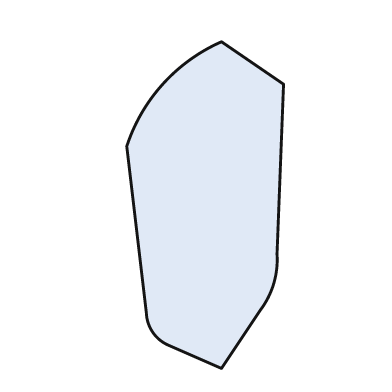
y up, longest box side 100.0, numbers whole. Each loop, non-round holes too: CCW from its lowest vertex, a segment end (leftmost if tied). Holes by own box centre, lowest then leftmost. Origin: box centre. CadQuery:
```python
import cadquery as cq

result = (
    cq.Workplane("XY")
    .moveTo(5.0, -50.0)
    .lineTo(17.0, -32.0)
    .threePointArc((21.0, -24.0), (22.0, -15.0))
    .lineTo(24.0, 37.0)
    .lineTo(5.0, 50.0)
    .threePointArc((-13.0, 37.0), (-24.0, 18.0))
    .lineTo(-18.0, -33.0)
    .threePointArc((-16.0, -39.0), (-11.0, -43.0))
    .close()
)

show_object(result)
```